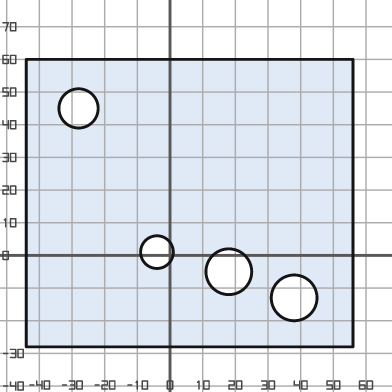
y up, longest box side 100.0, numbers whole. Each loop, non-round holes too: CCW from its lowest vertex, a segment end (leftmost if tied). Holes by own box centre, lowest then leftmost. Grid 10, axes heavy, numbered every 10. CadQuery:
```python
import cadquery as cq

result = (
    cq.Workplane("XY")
    .moveTo(-44.0, -28.0)
    .lineTo(56.0, -28.0)
    .lineTo(56.0, 60.0)
    .lineTo(-44.0, 60.0)
    .close()
    .moveTo(38.0, -13.0)
    .circle(7.0)
    .moveTo(18.0, -5.0)
    .circle(7.0)
    .moveTo(-4.0, 1.0)
    .circle(5.0)
    .moveTo(-28.0, 45.0)
    .circle(6.0)
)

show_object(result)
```